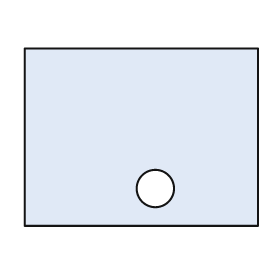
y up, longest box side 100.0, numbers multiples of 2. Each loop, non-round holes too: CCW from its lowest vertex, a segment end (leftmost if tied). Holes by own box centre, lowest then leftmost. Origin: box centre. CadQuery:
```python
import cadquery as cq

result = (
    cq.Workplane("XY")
    .moveTo(-50.0, -38.0)
    .lineTo(50.0, -38.0)
    .lineTo(50.0, 38.0)
    .lineTo(-50.0, 38.0)
    .close()
    .moveTo(6.0, -22.0)
    .circle(8.0)
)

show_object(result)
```